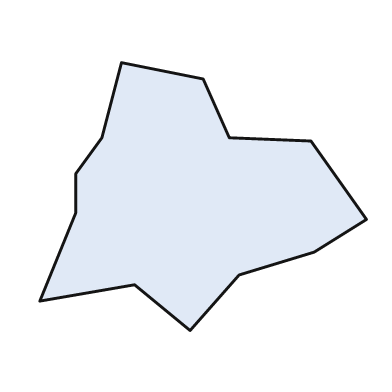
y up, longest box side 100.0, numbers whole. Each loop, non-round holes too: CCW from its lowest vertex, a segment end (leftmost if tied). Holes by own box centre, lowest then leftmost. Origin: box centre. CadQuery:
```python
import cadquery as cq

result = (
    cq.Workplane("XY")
    .moveTo(-4.0, -41.0)
    .lineTo(11.0, -24.0)
    .lineTo(34.0, -17.0)
    .lineTo(50.0, -7.0)
    .lineTo(33.0, 17.0)
    .lineTo(8.0, 18.0)
    .lineTo(0.0, 36.0)
    .lineTo(-25.0, 41.0)
    .lineTo(-31.0, 18.0)
    .lineTo(-39.0, 7.0)
    .lineTo(-39.0, -5.0)
    .lineTo(-50.0, -32.0)
    .lineTo(-21.0, -27.0)
    .close()
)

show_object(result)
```